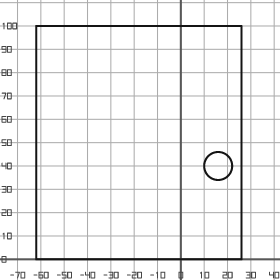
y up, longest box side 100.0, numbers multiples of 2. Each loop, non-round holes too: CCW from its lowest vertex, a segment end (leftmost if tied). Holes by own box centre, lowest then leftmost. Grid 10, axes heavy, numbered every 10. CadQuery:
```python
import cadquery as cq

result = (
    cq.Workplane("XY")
    .moveTo(-62.0, 0.0)
    .lineTo(26.0, 0.0)
    .lineTo(26.0, 100.0)
    .lineTo(-62.0, 100.0)
    .close()
    .moveTo(16.0, 40.0)
    .circle(6.0)
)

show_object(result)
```